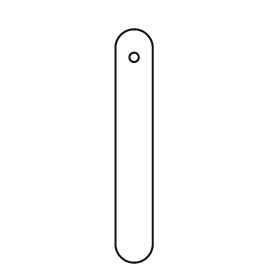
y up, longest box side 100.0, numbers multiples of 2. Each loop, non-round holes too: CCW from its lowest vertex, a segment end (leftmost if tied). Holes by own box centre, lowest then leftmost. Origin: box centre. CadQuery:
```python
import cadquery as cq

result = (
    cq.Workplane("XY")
    .moveTo(-8.0, -42.0)
    .threePointArc((0.0, -50.0), (8.0, -42.0))
    .lineTo(8.0, 42.0)
    .threePointArc((0.0, 50.0), (-8.0, 42.0))
    .close()
    .moveTo(0.0, 38.0)
    .circle(2.0)
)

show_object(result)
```